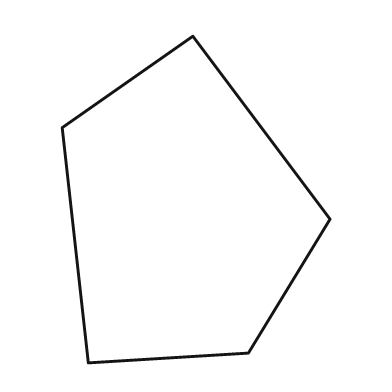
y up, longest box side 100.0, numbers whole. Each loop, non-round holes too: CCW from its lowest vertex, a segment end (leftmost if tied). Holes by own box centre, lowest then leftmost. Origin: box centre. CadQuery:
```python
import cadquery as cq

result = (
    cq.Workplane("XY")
    .moveTo(-33.0, -50.0)
    .lineTo(16.0, -47.0)
    .lineTo(41.0, -6.0)
    .lineTo(-1.0, 50.0)
    .lineTo(-41.0, 22.0)
    .close()
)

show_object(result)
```